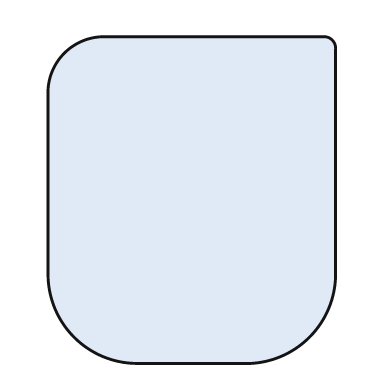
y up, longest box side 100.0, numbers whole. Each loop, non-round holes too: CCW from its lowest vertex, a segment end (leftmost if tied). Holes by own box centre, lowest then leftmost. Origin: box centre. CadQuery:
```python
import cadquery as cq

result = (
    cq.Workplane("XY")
    .moveTo(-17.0, -50.0)
    .lineTo(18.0, -50.0)
    .threePointArc((36.0, -42.0), (44.0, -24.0))
    .lineTo(44.0, 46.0)
    .threePointArc((43.0, 49.0), (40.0, 50.0))
    .lineTo(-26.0, 50.0)
    .threePointArc((-39.0, 45.0), (-44.0, 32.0))
    .lineTo(-44.0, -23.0)
    .threePointArc((-36.0, -42.0), (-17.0, -50.0))
    .close()
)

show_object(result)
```